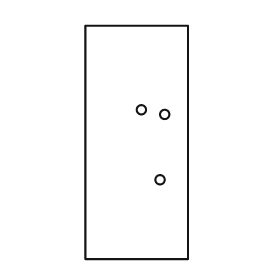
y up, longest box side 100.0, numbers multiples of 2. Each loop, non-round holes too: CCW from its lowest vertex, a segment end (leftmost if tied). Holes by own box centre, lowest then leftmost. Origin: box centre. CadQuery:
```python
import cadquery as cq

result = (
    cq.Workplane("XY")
    .moveTo(-22.0, -50.0)
    .lineTo(22.0, -50.0)
    .lineTo(22.0, 50.0)
    .lineTo(-22.0, 50.0)
    .close()
    .moveTo(10.0, -16.0)
    .circle(2.0)
    .moveTo(12.0, 12.0)
    .circle(2.0)
    .moveTo(2.0, 14.0)
    .circle(2.0)
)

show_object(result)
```